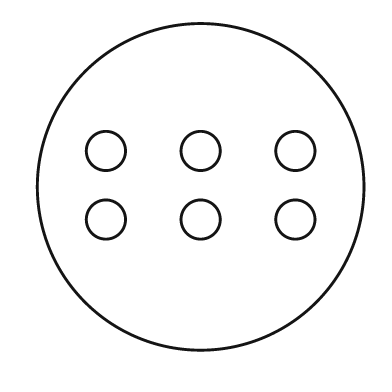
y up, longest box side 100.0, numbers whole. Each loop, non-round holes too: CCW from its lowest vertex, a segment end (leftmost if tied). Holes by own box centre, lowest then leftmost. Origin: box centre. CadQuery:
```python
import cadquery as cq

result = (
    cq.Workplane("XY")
    .moveTo(0.0, 0.0)
    .circle(50.0)
    .moveTo(-29.0, -10.0)
    .circle(6.0)
    .moveTo(0.0, -10.0)
    .circle(6.0)
    .moveTo(29.0, -10.0)
    .circle(6.0)
    .moveTo(-29.0, 11.0)
    .circle(6.0)
    .moveTo(0.0, 11.0)
    .circle(6.0)
    .moveTo(29.0, 11.0)
    .circle(6.0)
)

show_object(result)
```